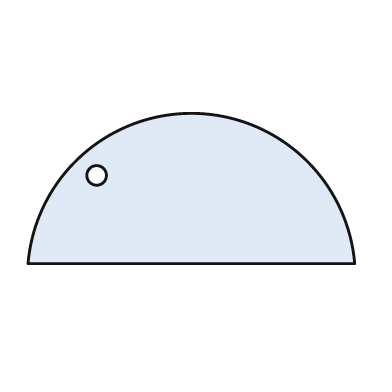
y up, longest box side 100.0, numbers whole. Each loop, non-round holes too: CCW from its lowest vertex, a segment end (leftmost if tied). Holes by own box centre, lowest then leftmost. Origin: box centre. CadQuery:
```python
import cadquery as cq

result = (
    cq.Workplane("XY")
    .moveTo(-50.0, -23.0)
    .lineTo(50.0, -23.0)
    .threePointArc((0.0, 23.0), (-50.0, -23.0))
    .close()
    .moveTo(-29.0, 4.0)
    .circle(3.0)
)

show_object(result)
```